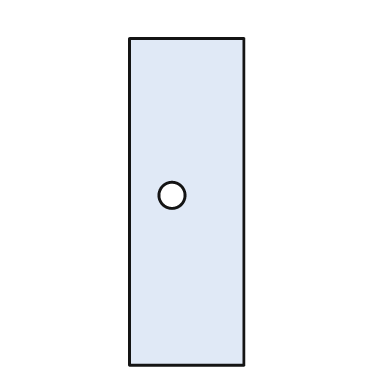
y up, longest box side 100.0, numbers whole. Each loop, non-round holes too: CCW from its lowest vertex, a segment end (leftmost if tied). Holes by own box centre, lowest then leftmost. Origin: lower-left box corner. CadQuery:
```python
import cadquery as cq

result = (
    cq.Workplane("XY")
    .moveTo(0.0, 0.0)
    .lineTo(35.0, 0.0)
    .lineTo(35.0, 100.0)
    .lineTo(0.0, 100.0)
    .close()
    .moveTo(13.0, 52.0)
    .circle(4.0)
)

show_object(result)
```